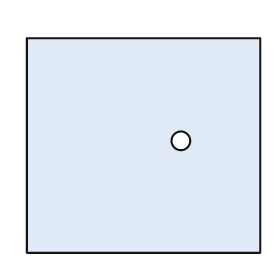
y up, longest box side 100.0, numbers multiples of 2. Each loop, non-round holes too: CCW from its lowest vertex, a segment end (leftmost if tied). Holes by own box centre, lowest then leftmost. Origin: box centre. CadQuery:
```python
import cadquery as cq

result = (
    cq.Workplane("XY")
    .moveTo(-50.0, -46.0)
    .lineTo(50.0, -46.0)
    .lineTo(50.0, 46.0)
    .lineTo(-50.0, 46.0)
    .close()
    .moveTo(16.0, 2.0)
    .circle(4.0)
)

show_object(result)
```